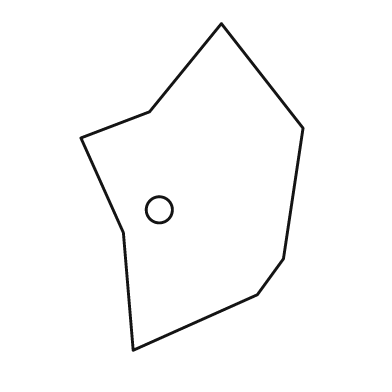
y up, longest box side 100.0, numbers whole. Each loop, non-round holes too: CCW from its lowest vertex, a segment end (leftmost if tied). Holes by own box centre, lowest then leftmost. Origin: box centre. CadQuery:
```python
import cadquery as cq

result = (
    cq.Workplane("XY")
    .moveTo(-18.0, -50.0)
    .lineTo(20.0, -33.0)
    .lineTo(28.0, -22.0)
    .lineTo(34.0, 18.0)
    .lineTo(9.0, 50.0)
    .lineTo(-13.0, 23.0)
    .lineTo(-34.0, 15.0)
    .lineTo(-21.0, -14.0)
    .close()
    .moveTo(-10.0, -7.0)
    .circle(4.0)
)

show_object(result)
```